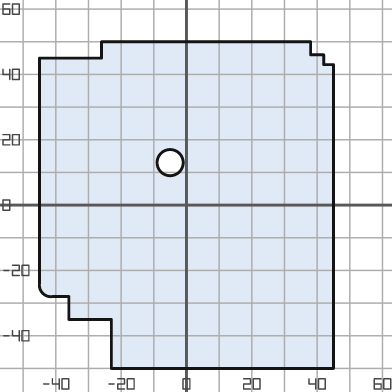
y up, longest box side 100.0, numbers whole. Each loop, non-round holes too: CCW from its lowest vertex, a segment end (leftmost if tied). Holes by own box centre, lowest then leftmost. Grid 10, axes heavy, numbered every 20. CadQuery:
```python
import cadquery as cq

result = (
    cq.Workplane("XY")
    .moveTo(-23.0, -50.0)
    .lineTo(45.0, -50.0)
    .lineTo(45.0, 43.0)
    .lineTo(42.0, 43.0)
    .lineTo(42.0, 46.0)
    .lineTo(38.0, 46.0)
    .lineTo(38.0, 50.0)
    .lineTo(-26.0, 50.0)
    .lineTo(-26.0, 45.0)
    .lineTo(-45.0, 45.0)
    .lineTo(-45.0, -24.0)
    .threePointArc((-44.0, -27.0), (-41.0, -28.0))
    .lineTo(-36.0, -28.0)
    .lineTo(-36.0, -35.0)
    .lineTo(-23.0, -35.0)
    .close()
    .moveTo(-5.0, 13.0)
    .circle(4.0)
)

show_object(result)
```